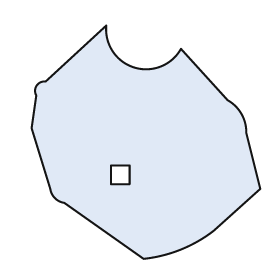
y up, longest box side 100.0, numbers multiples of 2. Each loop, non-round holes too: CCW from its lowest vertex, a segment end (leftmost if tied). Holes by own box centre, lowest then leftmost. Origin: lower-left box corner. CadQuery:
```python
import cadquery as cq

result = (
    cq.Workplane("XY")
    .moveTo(48.0, 0.0)
    .threePointArc((64.0, 4.0), (78.0, 12.0))
    .lineTo(98.0, 30.0)
    .lineTo(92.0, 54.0)
    .threePointArc((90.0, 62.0), (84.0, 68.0))
    .lineTo(64.0, 90.0)
    .threePointArc((44.0, 82.0), (32.0, 100.0))
    .lineTo(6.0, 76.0)
    .threePointArc((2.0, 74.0), (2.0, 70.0))
    .lineTo(0.0, 56.0)
    .lineTo(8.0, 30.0)
    .threePointArc((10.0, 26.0), (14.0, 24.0))
    .close()
    .moveTo(34.0, 32.0)
    .lineTo(42.0, 32.0)
    .lineTo(42.0, 40.0)
    .lineTo(34.0, 40.0)
    .close()
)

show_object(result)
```